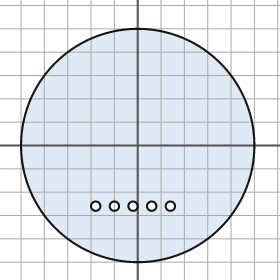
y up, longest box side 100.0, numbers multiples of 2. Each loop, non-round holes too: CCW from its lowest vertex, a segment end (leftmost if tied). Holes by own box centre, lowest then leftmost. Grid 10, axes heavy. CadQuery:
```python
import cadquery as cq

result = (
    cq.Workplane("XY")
    .moveTo(0.0, 0.0)
    .circle(50.0)
    .moveTo(-18.0, -26.0)
    .circle(2.0)
    .moveTo(-10.0, -26.0)
    .circle(2.0)
    .moveTo(-2.0, -26.0)
    .circle(2.0)
    .moveTo(6.0, -26.0)
    .circle(2.0)
    .moveTo(14.0, -26.0)
    .circle(2.0)
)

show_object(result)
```